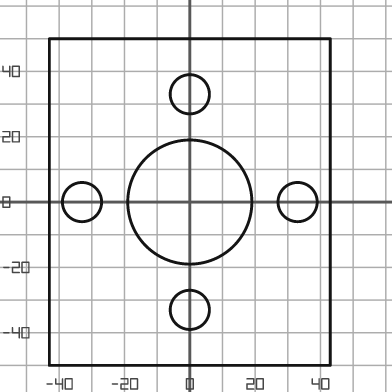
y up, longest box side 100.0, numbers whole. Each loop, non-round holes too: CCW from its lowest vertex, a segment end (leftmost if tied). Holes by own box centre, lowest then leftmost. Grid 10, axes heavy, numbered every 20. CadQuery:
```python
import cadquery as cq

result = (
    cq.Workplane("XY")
    .moveTo(-43.0, -50.0)
    .lineTo(43.0, -50.0)
    .lineTo(43.0, 50.0)
    .lineTo(-43.0, 50.0)
    .close()
    .moveTo(0.0, -33.0)
    .circle(6.0)
    .moveTo(-33.0, 0.0)
    .circle(6.0)
    .moveTo(0.0, 0.0)
    .circle(19.0)
    .moveTo(33.0, 0.0)
    .circle(6.0)
    .moveTo(0.0, 33.0)
    .circle(6.0)
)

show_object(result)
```